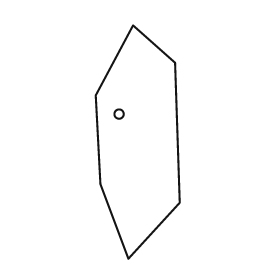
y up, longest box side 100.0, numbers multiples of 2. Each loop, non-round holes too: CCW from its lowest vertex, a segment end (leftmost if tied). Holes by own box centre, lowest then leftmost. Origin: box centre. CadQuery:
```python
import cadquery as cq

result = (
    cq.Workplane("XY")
    .moveTo(-4.0, -50.0)
    .lineTo(18.0, -26.0)
    .lineTo(16.0, 34.0)
    .lineTo(-2.0, 50.0)
    .lineTo(-18.0, 20.0)
    .lineTo(-16.0, -18.0)
    .close()
    .moveTo(-8.0, 12.0)
    .circle(2.0)
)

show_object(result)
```